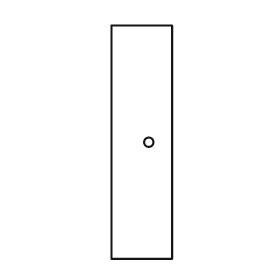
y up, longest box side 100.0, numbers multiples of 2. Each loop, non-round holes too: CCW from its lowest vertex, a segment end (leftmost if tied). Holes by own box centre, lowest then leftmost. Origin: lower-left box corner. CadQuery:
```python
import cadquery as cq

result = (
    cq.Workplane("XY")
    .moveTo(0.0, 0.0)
    .lineTo(26.0, 0.0)
    .lineTo(26.0, 100.0)
    .lineTo(0.0, 100.0)
    .close()
    .moveTo(16.0, 50.0)
    .circle(2.0)
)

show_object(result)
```